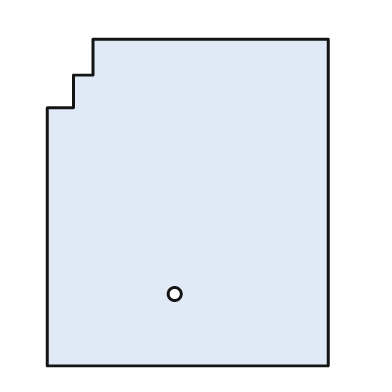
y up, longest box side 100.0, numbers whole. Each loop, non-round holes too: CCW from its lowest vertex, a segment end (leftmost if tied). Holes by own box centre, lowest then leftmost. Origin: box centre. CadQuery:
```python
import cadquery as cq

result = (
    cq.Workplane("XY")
    .moveTo(-43.0, -50.0)
    .lineTo(43.0, -50.0)
    .lineTo(43.0, 50.0)
    .lineTo(-29.0, 50.0)
    .lineTo(-29.0, 39.0)
    .lineTo(-35.0, 39.0)
    .lineTo(-35.0, 29.0)
    .lineTo(-43.0, 29.0)
    .close()
    .moveTo(-4.0, -28.0)
    .circle(2.0)
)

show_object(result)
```